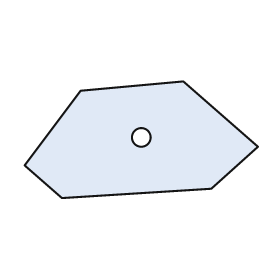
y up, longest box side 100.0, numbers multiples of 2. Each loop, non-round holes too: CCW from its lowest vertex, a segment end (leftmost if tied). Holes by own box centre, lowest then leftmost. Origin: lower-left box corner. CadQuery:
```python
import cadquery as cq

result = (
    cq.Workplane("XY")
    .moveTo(16.0, 0.0)
    .lineTo(80.0, 4.0)
    .lineTo(100.0, 22.0)
    .lineTo(68.0, 50.0)
    .lineTo(24.0, 46.0)
    .lineTo(0.0, 14.0)
    .close()
    .moveTo(50.0, 26.0)
    .circle(4.0)
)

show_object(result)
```